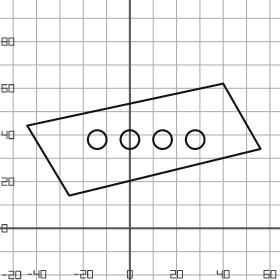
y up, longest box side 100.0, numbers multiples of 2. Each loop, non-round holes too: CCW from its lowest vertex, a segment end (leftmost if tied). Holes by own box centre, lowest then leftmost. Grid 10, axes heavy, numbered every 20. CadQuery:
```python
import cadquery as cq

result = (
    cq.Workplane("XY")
    .moveTo(-26.0, 14.0)
    .lineTo(56.0, 34.0)
    .lineTo(40.0, 62.0)
    .lineTo(-44.0, 44.0)
    .close()
    .moveTo(-14.0, 38.0)
    .circle(4.0)
    .moveTo(0.0, 38.0)
    .circle(4.0)
    .moveTo(14.0, 38.0)
    .circle(4.0)
    .moveTo(28.0, 38.0)
    .circle(4.0)
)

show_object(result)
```